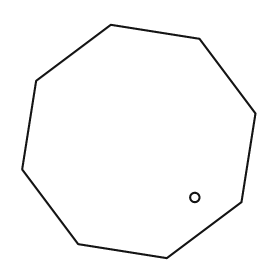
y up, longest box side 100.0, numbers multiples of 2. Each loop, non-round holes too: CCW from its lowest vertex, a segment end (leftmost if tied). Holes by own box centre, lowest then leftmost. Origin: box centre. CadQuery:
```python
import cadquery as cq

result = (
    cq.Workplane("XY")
    .moveTo(12.0, -50.0)
    .lineTo(44.0, -26.0)
    .lineTo(50.0, 12.0)
    .lineTo(26.0, 44.0)
    .lineTo(-12.0, 50.0)
    .lineTo(-44.0, 26.0)
    .lineTo(-50.0, -12.0)
    .lineTo(-26.0, -44.0)
    .close()
    .moveTo(24.0, -24.0)
    .circle(2.0)
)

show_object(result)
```